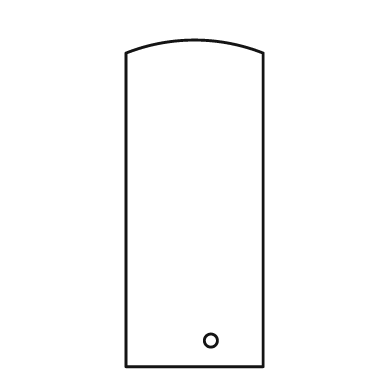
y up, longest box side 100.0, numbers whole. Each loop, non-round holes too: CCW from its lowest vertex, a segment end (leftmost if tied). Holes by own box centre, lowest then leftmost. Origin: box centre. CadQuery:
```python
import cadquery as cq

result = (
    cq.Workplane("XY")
    .moveTo(-21.0, -50.0)
    .lineTo(21.0, -50.0)
    .lineTo(21.0, 46.0)
    .threePointArc((0.0, 50.0), (-21.0, 46.0))
    .close()
    .moveTo(5.0, -42.0)
    .circle(2.0)
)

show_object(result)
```